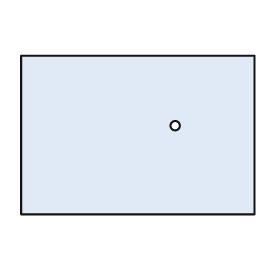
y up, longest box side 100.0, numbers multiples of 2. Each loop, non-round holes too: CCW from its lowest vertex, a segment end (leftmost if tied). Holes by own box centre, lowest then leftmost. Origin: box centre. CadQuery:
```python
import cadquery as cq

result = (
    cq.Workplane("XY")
    .moveTo(-50.0, -34.0)
    .lineTo(50.0, -34.0)
    .lineTo(50.0, 34.0)
    .lineTo(-50.0, 34.0)
    .close()
    .moveTo(16.0, 4.0)
    .circle(2.0)
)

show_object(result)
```